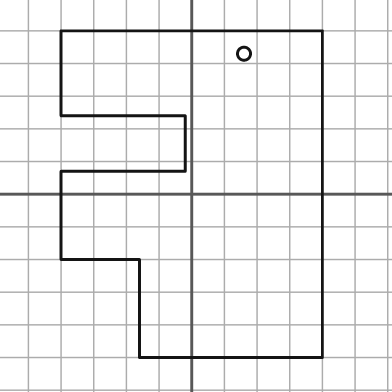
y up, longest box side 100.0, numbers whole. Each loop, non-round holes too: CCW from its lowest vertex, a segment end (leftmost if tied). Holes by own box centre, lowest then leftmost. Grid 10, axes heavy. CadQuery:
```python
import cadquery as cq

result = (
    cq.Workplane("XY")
    .moveTo(-16.0, -50.0)
    .lineTo(40.0, -50.0)
    .lineTo(40.0, 50.0)
    .lineTo(-40.0, 50.0)
    .lineTo(-40.0, 24.0)
    .lineTo(-2.0, 24.0)
    .lineTo(-2.0, 7.0)
    .lineTo(-40.0, 7.0)
    .lineTo(-40.0, -20.0)
    .lineTo(-16.0, -20.0)
    .close()
    .moveTo(16.0, 43.0)
    .circle(2.0)
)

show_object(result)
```